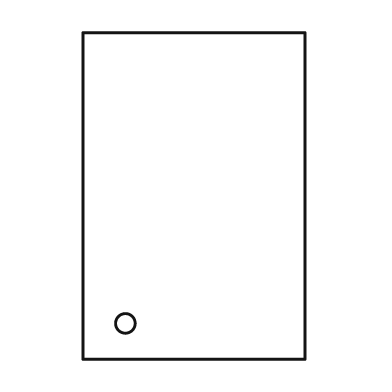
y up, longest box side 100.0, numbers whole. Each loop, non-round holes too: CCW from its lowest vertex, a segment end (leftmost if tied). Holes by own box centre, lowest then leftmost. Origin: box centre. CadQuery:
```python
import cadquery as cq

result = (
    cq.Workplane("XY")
    .moveTo(-34.0, -50.0)
    .lineTo(34.0, -50.0)
    .lineTo(34.0, 50.0)
    .lineTo(-34.0, 50.0)
    .close()
    .moveTo(-21.0, -39.0)
    .circle(3.0)
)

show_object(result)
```